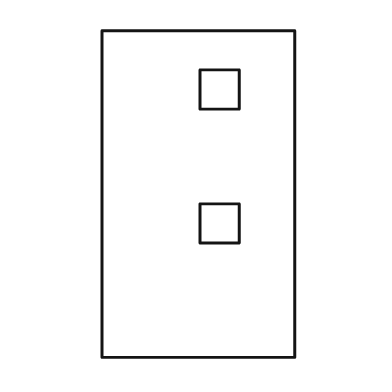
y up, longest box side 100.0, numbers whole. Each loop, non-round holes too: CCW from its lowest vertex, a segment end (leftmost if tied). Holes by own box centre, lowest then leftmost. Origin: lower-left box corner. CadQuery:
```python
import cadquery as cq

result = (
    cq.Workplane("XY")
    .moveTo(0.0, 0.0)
    .lineTo(59.0, 0.0)
    .lineTo(59.0, 100.0)
    .lineTo(0.0, 100.0)
    .close()
    .moveTo(30.0, 35.0)
    .lineTo(42.0, 35.0)
    .lineTo(42.0, 47.0)
    .lineTo(30.0, 47.0)
    .close()
    .moveTo(30.0, 76.0)
    .lineTo(42.0, 76.0)
    .lineTo(42.0, 88.0)
    .lineTo(30.0, 88.0)
    .close()
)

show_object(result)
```